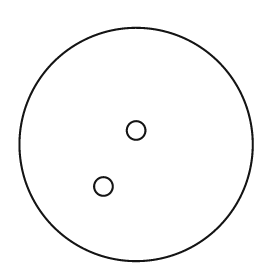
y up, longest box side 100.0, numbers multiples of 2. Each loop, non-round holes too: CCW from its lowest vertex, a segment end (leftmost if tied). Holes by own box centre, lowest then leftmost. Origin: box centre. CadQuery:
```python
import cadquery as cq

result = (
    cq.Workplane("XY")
    .moveTo(0.0, 0.0)
    .circle(50.0)
    .moveTo(-14.0, -18.0)
    .circle(4.0)
    .moveTo(0.0, 6.0)
    .circle(4.0)
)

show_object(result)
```